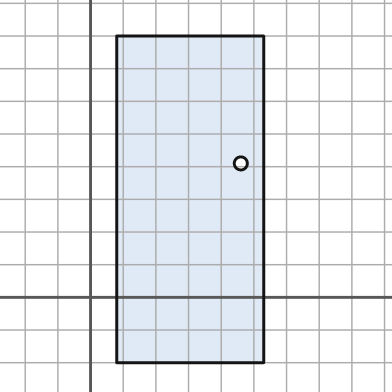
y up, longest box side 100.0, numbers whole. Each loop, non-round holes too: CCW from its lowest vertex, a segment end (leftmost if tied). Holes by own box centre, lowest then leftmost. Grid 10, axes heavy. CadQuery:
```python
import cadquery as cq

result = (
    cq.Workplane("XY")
    .moveTo(8.0, -20.0)
    .lineTo(53.0, -20.0)
    .lineTo(53.0, 80.0)
    .lineTo(8.0, 80.0)
    .close()
    .moveTo(46.0, 41.0)
    .circle(2.0)
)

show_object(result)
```